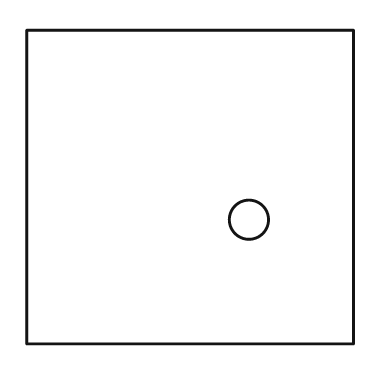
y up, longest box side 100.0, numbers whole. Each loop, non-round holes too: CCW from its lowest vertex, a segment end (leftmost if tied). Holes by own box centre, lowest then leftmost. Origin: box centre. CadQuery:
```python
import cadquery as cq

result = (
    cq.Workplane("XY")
    .moveTo(-50.0, -48.0)
    .lineTo(50.0, -48.0)
    .lineTo(50.0, 48.0)
    .lineTo(-50.0, 48.0)
    .close()
    .moveTo(18.0, -10.0)
    .circle(6.0)
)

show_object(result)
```